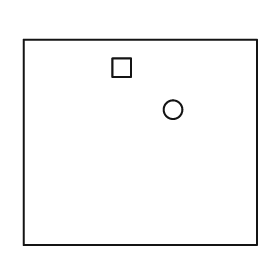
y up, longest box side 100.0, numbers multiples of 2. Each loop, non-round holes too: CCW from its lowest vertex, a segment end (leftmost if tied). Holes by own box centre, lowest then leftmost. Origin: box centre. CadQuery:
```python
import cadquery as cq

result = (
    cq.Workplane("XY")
    .moveTo(-50.0, -44.0)
    .lineTo(50.0, -44.0)
    .lineTo(50.0, 44.0)
    .lineTo(-50.0, 44.0)
    .close()
    .moveTo(14.0, 14.0)
    .circle(4.0)
    .moveTo(-12.0, 28.0)
    .lineTo(-4.0, 28.0)
    .lineTo(-4.0, 36.0)
    .lineTo(-12.0, 36.0)
    .close()
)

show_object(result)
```